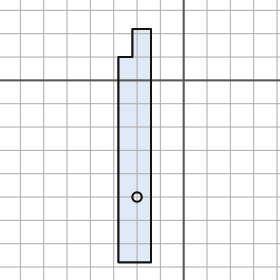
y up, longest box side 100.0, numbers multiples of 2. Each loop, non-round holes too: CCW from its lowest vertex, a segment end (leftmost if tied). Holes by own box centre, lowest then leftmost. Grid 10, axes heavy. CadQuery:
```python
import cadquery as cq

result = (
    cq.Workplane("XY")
    .moveTo(-28.0, -78.0)
    .lineTo(-14.0, -78.0)
    .lineTo(-14.0, 22.0)
    .lineTo(-22.0, 22.0)
    .lineTo(-22.0, 10.0)
    .lineTo(-28.0, 10.0)
    .close()
    .moveTo(-20.0, -50.0)
    .circle(2.0)
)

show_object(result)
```